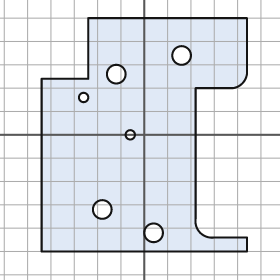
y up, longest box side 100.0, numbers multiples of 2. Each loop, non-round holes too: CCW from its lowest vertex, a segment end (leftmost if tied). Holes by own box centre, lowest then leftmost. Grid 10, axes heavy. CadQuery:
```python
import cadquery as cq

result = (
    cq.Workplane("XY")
    .moveTo(-44.0, -50.0)
    .lineTo(44.0, -50.0)
    .lineTo(44.0, -44.0)
    .lineTo(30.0, -44.0)
    .threePointArc((24.0, -42.0), (22.0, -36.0))
    .lineTo(22.0, 20.0)
    .lineTo(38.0, 20.0)
    .threePointArc((42.0, 22.0), (44.0, 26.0))
    .lineTo(44.0, 50.0)
    .lineTo(-24.0, 50.0)
    .lineTo(-24.0, 24.0)
    .lineTo(-44.0, 24.0)
    .close()
    .moveTo(4.0, -42.0)
    .circle(4.0)
    .moveTo(-18.0, -32.0)
    .circle(4.0)
    .moveTo(-6.0, 0.0)
    .circle(2.0)
    .moveTo(-26.0, 16.0)
    .circle(2.0)
    .moveTo(-12.0, 26.0)
    .circle(4.0)
    .moveTo(16.0, 34.0)
    .circle(4.0)
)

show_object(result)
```